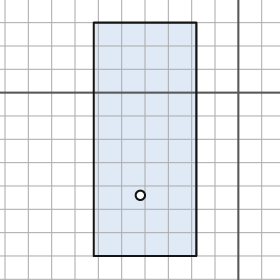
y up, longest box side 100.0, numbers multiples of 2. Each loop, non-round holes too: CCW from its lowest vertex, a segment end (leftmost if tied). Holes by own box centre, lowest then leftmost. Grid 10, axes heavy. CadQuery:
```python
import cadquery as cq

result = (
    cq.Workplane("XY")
    .moveTo(-62.0, -70.0)
    .lineTo(-18.0, -70.0)
    .lineTo(-18.0, 30.0)
    .lineTo(-62.0, 30.0)
    .close()
    .moveTo(-42.0, -44.0)
    .circle(2.0)
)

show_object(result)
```